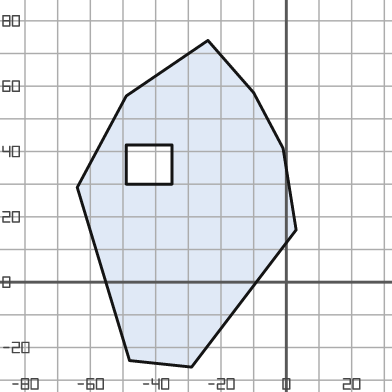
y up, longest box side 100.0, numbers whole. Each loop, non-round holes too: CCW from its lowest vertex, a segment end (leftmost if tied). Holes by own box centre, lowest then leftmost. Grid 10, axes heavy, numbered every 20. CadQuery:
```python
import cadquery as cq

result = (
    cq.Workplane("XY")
    .moveTo(-29.0, -26.0)
    .lineTo(3.0, 16.0)
    .lineTo(-1.0, 41.0)
    .lineTo(-10.0, 58.0)
    .lineTo(-24.0, 74.0)
    .lineTo(-49.0, 57.0)
    .lineTo(-64.0, 29.0)
    .lineTo(-48.0, -24.0)
    .close()
    .moveTo(-49.0, 30.0)
    .lineTo(-35.0, 30.0)
    .lineTo(-35.0, 42.0)
    .lineTo(-49.0, 42.0)
    .close()
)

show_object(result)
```